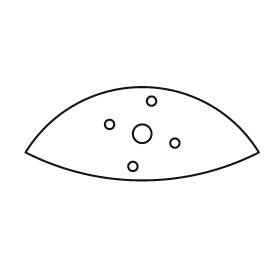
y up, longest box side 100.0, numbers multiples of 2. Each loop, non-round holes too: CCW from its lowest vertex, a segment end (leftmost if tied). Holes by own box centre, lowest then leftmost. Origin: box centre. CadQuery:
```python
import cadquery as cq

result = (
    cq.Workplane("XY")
    .moveTo(-50.0, -8.0)
    .threePointArc((0.0, -20.0), (50.0, -8.0))
    .threePointArc((0.0, 20.0), (-50.0, -8.0))
    .close()
    .moveTo(-4.0, -14.0)
    .circle(2.0)
    .moveTo(14.0, -4.0)
    .circle(2.0)
    .moveTo(0.0, 0.0)
    .circle(4.0)
    .moveTo(-14.0, 4.0)
    .circle(2.0)
    .moveTo(4.0, 14.0)
    .circle(2.0)
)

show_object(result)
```